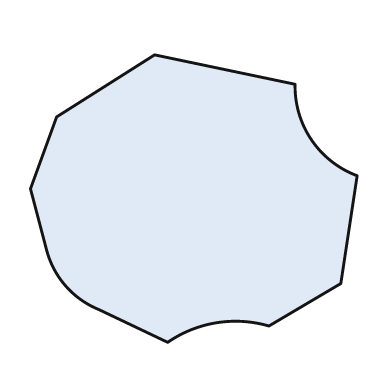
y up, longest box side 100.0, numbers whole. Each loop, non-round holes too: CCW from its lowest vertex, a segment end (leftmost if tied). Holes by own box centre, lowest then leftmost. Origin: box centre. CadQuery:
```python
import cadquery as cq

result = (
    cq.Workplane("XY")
    .moveTo(-8.0, -44.0)
    .threePointArc((7.0, -38.0), (23.0, -39.0))
    .lineTo(45.0, -26.0)
    .lineTo(50.0, 7.0)
    .threePointArc((36.0, 18.0), (31.0, 35.0))
    .lineTo(-12.0, 44.0)
    .lineTo(-42.0, 25.0)
    .lineTo(-50.0, 3.0)
    .lineTo(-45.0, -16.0)
    .threePointArc((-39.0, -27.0), (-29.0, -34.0))
    .close()
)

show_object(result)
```